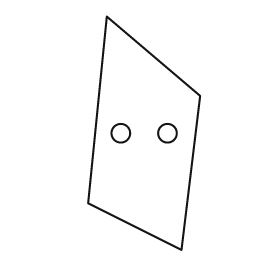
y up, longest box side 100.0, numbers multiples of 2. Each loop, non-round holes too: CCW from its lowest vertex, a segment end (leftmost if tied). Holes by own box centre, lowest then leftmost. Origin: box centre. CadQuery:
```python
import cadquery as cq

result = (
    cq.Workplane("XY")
    .moveTo(16.0, -50.0)
    .lineTo(24.0, 16.0)
    .lineTo(-16.0, 50.0)
    .lineTo(-24.0, -30.0)
    .close()
    .moveTo(-10.0, 0.0)
    .circle(4.0)
    .moveTo(10.0, 0.0)
    .circle(4.0)
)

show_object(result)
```